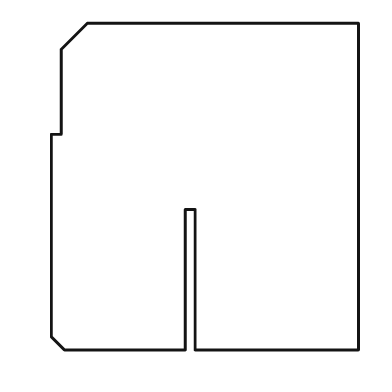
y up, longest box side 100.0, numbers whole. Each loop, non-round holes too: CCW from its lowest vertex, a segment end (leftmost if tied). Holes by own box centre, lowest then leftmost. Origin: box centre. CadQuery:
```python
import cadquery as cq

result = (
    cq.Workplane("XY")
    .moveTo(-43.0, -50.0)
    .lineTo(-6.0, -50.0)
    .lineTo(-6.0, -7.0)
    .lineTo(-3.0, -7.0)
    .lineTo(-3.0, -50.0)
    .lineTo(47.0, -50.0)
    .lineTo(47.0, 50.0)
    .lineTo(-36.0, 50.0)
    .lineTo(-44.0, 42.0)
    .lineTo(-44.0, 16.0)
    .lineTo(-47.0, 16.0)
    .lineTo(-47.0, -46.0)
    .close()
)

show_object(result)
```